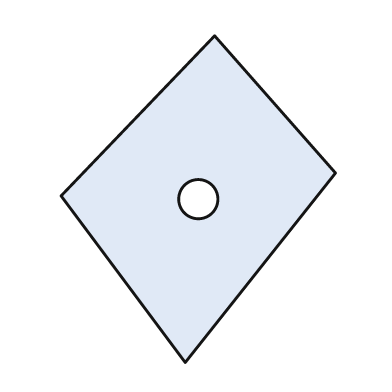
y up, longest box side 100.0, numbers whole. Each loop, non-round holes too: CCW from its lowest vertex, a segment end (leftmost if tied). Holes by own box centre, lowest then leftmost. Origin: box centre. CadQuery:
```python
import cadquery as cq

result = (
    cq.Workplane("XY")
    .moveTo(-4.0, -50.0)
    .lineTo(42.0, 8.0)
    .lineTo(5.0, 50.0)
    .lineTo(-42.0, 1.0)
    .close()
    .moveTo(0.0, 0.0)
    .circle(6.0)
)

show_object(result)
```